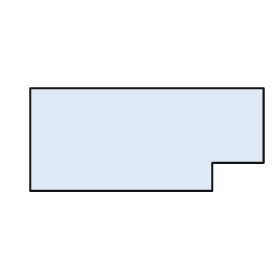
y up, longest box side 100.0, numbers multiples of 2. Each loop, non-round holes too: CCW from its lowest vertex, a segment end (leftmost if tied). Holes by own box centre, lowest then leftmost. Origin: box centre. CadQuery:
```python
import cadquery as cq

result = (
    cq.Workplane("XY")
    .moveTo(-50.0, -22.0)
    .lineTo(28.0, -22.0)
    .lineTo(28.0, -10.0)
    .lineTo(50.0, -10.0)
    .lineTo(50.0, 22.0)
    .lineTo(-50.0, 22.0)
    .close()
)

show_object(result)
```